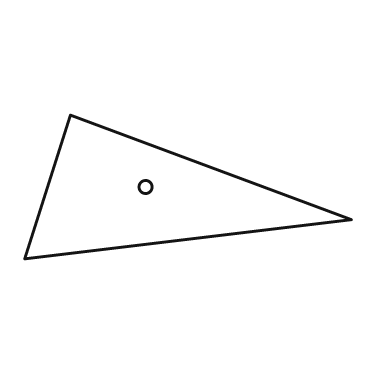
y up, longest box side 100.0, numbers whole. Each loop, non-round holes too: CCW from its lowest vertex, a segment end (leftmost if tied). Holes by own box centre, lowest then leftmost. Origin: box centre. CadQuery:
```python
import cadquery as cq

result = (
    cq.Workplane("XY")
    .moveTo(-50.0, -22.0)
    .lineTo(50.0, -10.0)
    .lineTo(-36.0, 22.0)
    .close()
    .moveTo(-13.0, 0.0)
    .circle(2.0)
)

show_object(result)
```